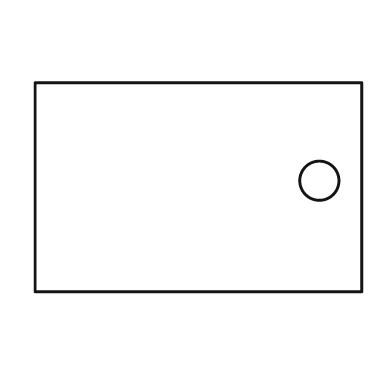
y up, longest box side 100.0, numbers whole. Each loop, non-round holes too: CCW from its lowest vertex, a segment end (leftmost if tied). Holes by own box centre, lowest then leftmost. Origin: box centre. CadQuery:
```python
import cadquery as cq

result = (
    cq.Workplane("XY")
    .moveTo(-50.0, -32.0)
    .lineTo(50.0, -32.0)
    .lineTo(50.0, 32.0)
    .lineTo(-50.0, 32.0)
    .close()
    .moveTo(37.0, 2.0)
    .circle(6.0)
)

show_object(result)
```